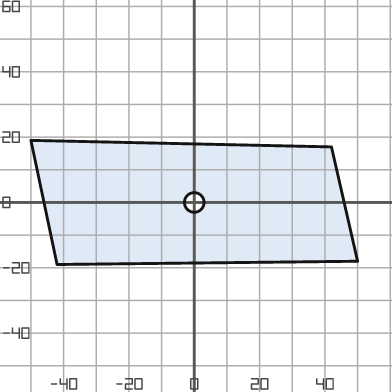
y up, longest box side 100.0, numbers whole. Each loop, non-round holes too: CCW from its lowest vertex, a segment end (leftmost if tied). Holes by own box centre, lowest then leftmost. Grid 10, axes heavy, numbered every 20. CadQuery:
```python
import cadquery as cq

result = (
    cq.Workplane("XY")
    .moveTo(-42.0, -19.0)
    .lineTo(50.0, -18.0)
    .lineTo(42.0, 17.0)
    .lineTo(-50.0, 19.0)
    .close()
    .moveTo(0.0, 0.0)
    .circle(3.0)
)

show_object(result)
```